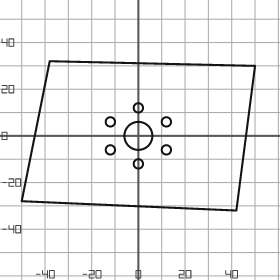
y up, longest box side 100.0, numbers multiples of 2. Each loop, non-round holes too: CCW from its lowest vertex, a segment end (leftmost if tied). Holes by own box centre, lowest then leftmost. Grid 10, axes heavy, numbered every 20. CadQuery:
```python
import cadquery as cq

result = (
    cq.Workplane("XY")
    .moveTo(42.0, -32.0)
    .lineTo(50.0, 30.0)
    .lineTo(-38.0, 32.0)
    .lineTo(-50.0, -28.0)
    .close()
    .moveTo(0.0, -12.0)
    .circle(2.0)
    .moveTo(-12.0, -6.0)
    .circle(2.0)
    .moveTo(12.0, -6.0)
    .circle(2.0)
    .moveTo(0.0, 0.0)
    .circle(6.0)
    .moveTo(-12.0, 6.0)
    .circle(2.0)
    .moveTo(12.0, 6.0)
    .circle(2.0)
    .moveTo(0.0, 12.0)
    .circle(2.0)
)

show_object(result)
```